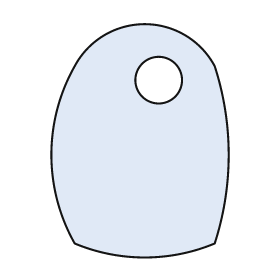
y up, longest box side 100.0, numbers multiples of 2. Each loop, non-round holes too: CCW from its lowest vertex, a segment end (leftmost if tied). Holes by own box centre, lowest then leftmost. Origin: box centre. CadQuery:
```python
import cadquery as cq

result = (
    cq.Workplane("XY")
    .moveTo(-28.0, -44.0)
    .threePointArc((2.0, -50.0), (32.0, -44.0))
    .threePointArc((38.0, -6.0), (32.0, 32.0))
    .threePointArc((2.0, 50.0), (-28.0, 32.0))
    .threePointArc((-38.0, -6.0), (-28.0, -44.0))
    .close()
    .moveTo(8.0, 26.0)
    .circle(10.0)
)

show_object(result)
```